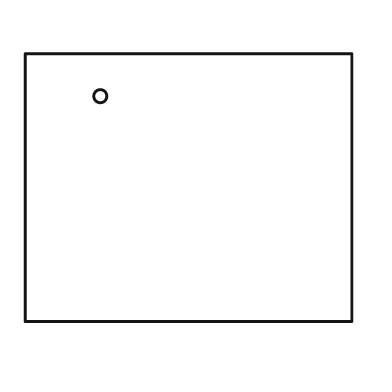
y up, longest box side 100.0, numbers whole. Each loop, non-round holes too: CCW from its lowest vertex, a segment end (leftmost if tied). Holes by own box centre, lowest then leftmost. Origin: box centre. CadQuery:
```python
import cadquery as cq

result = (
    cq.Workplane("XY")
    .moveTo(-50.0, -41.0)
    .lineTo(50.0, -41.0)
    .lineTo(50.0, 41.0)
    .lineTo(-50.0, 41.0)
    .close()
    .moveTo(-27.0, 28.0)
    .circle(2.0)
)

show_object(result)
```